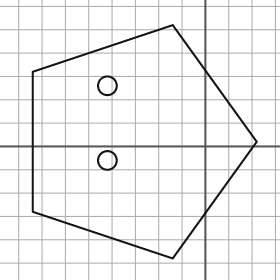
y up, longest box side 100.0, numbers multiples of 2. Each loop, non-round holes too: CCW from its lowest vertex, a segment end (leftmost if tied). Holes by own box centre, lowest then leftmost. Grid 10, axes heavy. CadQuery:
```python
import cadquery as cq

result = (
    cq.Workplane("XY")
    .moveTo(-14.0, -48.0)
    .lineTo(22.0, 2.0)
    .lineTo(-14.0, 52.0)
    .lineTo(-74.0, 32.0)
    .lineTo(-74.0, -28.0)
    .close()
    .moveTo(-42.0, -6.0)
    .circle(4.0)
    .moveTo(-42.0, 26.0)
    .circle(4.0)
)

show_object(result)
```